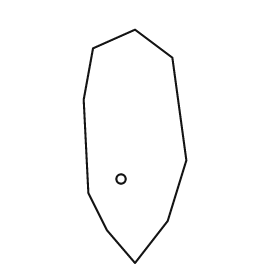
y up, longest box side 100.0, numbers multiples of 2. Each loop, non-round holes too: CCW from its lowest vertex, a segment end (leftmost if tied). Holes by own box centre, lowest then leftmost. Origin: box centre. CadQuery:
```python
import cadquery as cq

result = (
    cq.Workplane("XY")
    .moveTo(0.0, -50.0)
    .lineTo(14.0, -32.0)
    .lineTo(22.0, -6.0)
    .lineTo(16.0, 38.0)
    .lineTo(0.0, 50.0)
    .lineTo(-18.0, 42.0)
    .lineTo(-22.0, 20.0)
    .lineTo(-20.0, -20.0)
    .lineTo(-12.0, -36.0)
    .close()
    .moveTo(-6.0, -14.0)
    .circle(2.0)
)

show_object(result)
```